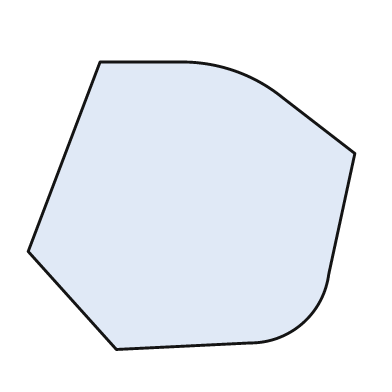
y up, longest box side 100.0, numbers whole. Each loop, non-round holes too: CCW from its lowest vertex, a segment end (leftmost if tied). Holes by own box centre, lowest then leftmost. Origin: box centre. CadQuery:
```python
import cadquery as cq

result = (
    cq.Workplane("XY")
    .moveTo(-23.0, -44.0)
    .lineTo(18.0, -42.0)
    .threePointArc((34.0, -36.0), (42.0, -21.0))
    .lineTo(50.0, 16.0)
    .lineTo(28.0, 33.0)
    .threePointArc((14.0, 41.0), (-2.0, 44.0))
    .lineTo(-28.0, 44.0)
    .lineTo(-50.0, -14.0)
    .close()
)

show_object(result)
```